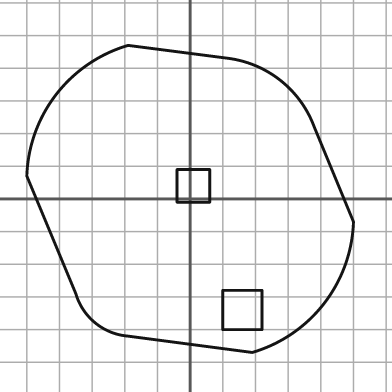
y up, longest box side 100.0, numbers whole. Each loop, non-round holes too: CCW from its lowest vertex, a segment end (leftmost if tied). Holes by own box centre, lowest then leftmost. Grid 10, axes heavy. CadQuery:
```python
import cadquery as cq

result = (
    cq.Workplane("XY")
    .moveTo(19.0, -47.0)
    .threePointArc((41.0, -32.0), (50.0, -7.0))
    .lineTo(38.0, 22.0)
    .threePointArc((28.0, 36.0), (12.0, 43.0))
    .lineTo(-19.0, 47.0)
    .threePointArc((-41.0, 32.0), (-50.0, 7.0))
    .lineTo(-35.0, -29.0)
    .threePointArc((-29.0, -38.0), (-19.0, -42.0))
    .close()
    .moveTo(10.0, -40.0)
    .lineTo(22.0, -40.0)
    .lineTo(22.0, -28.0)
    .lineTo(10.0, -28.0)
    .close()
    .moveTo(-4.0, -1.0)
    .lineTo(6.0, -1.0)
    .lineTo(6.0, 9.0)
    .lineTo(-4.0, 9.0)
    .close()
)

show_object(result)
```